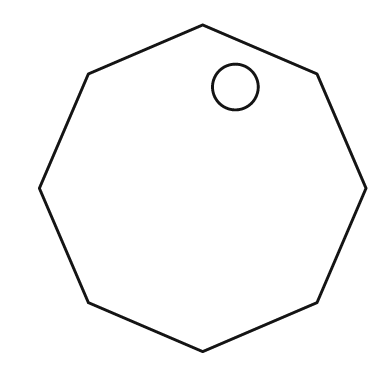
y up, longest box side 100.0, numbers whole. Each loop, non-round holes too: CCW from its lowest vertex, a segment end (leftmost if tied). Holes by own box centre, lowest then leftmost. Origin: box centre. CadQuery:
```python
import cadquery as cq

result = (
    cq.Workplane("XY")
    .moveTo(0.0, -50.0)
    .lineTo(35.0, -35.0)
    .lineTo(50.0, 0.0)
    .lineTo(35.0, 35.0)
    .lineTo(0.0, 50.0)
    .lineTo(-35.0, 35.0)
    .lineTo(-50.0, 0.0)
    .lineTo(-35.0, -35.0)
    .close()
    .moveTo(10.0, 31.0)
    .circle(7.0)
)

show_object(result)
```